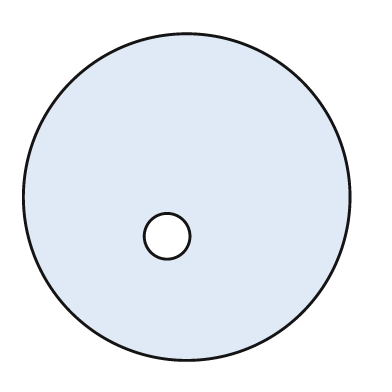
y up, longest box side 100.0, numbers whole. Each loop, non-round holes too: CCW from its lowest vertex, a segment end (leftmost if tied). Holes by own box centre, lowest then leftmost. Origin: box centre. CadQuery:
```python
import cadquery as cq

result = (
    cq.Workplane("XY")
    .moveTo(0.0, 0.0)
    .circle(50.0)
    .moveTo(-6.0, -12.0)
    .circle(7.0)
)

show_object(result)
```